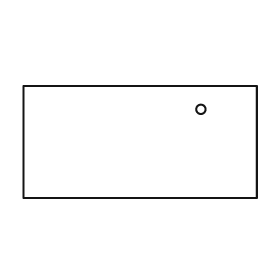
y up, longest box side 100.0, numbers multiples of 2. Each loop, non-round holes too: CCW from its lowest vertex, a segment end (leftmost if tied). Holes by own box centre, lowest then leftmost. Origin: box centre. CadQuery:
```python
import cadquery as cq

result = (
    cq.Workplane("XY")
    .moveTo(-50.0, -24.0)
    .lineTo(50.0, -24.0)
    .lineTo(50.0, 24.0)
    .lineTo(-50.0, 24.0)
    .close()
    .moveTo(26.0, 14.0)
    .circle(2.0)
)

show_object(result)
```